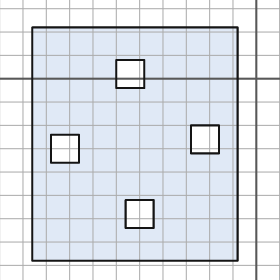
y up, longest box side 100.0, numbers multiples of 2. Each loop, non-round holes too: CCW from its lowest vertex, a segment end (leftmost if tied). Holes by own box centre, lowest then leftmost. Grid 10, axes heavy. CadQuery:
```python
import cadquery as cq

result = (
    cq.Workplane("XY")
    .moveTo(-96.0, -78.0)
    .lineTo(-8.0, -78.0)
    .lineTo(-8.0, 22.0)
    .lineTo(-96.0, 22.0)
    .close()
    .moveTo(-56.0, -64.0)
    .lineTo(-44.0, -64.0)
    .lineTo(-44.0, -52.0)
    .lineTo(-56.0, -52.0)
    .close()
    .moveTo(-88.0, -36.0)
    .lineTo(-76.0, -36.0)
    .lineTo(-76.0, -24.0)
    .lineTo(-88.0, -24.0)
    .close()
    .moveTo(-28.0, -32.0)
    .lineTo(-16.0, -32.0)
    .lineTo(-16.0, -20.0)
    .lineTo(-28.0, -20.0)
    .close()
    .moveTo(-60.0, -4.0)
    .lineTo(-48.0, -4.0)
    .lineTo(-48.0, 8.0)
    .lineTo(-60.0, 8.0)
    .close()
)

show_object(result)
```